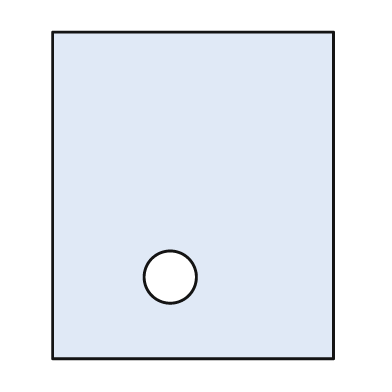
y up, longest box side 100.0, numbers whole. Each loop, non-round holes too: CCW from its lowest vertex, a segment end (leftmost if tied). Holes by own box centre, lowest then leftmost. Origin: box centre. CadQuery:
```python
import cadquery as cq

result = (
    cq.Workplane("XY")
    .moveTo(-43.0, -50.0)
    .lineTo(43.0, -50.0)
    .lineTo(43.0, 50.0)
    .lineTo(-43.0, 50.0)
    .close()
    .moveTo(-7.0, -25.0)
    .circle(8.0)
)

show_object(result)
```